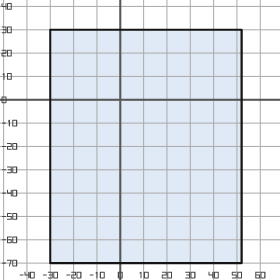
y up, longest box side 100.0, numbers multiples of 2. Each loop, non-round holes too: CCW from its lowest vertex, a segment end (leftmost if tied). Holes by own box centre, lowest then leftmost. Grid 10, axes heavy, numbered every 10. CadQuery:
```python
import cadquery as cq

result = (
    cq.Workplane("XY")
    .moveTo(-30.0, -70.0)
    .lineTo(52.0, -70.0)
    .lineTo(52.0, 30.0)
    .lineTo(-30.0, 30.0)
    .close()
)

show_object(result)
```